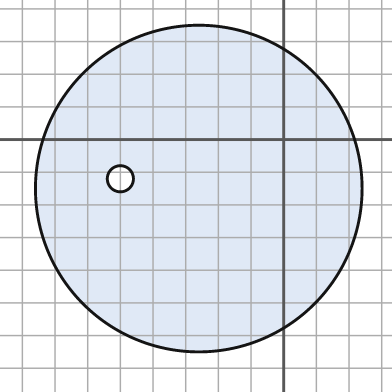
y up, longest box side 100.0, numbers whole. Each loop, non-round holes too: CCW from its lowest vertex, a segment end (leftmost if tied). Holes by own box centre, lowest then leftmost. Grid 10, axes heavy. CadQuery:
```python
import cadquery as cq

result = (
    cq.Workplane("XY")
    .moveTo(-26.0, -15.0)
    .circle(50.0)
    .moveTo(-50.0, -12.0)
    .circle(4.0)
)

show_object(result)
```